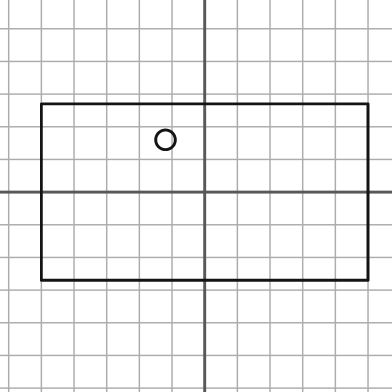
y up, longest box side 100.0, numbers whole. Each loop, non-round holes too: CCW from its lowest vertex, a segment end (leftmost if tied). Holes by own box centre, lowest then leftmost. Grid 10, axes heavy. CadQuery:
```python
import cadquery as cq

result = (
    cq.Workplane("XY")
    .moveTo(-50.0, -27.0)
    .lineTo(50.0, -27.0)
    .lineTo(50.0, 27.0)
    .lineTo(-50.0, 27.0)
    .close()
    .moveTo(-12.0, 16.0)
    .circle(3.0)
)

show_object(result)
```